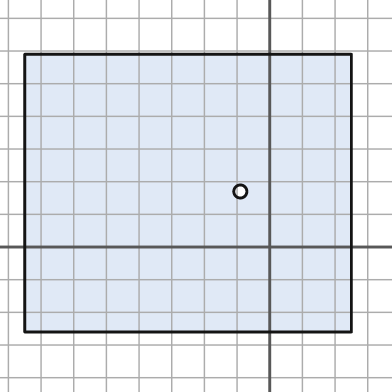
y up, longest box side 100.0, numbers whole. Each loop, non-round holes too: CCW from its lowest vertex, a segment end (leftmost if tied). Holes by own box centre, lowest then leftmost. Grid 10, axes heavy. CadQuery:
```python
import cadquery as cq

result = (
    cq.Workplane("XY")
    .moveTo(-75.0, -26.0)
    .lineTo(25.0, -26.0)
    .lineTo(25.0, 59.0)
    .lineTo(-75.0, 59.0)
    .close()
    .moveTo(-9.0, 17.0)
    .circle(2.0)
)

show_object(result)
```